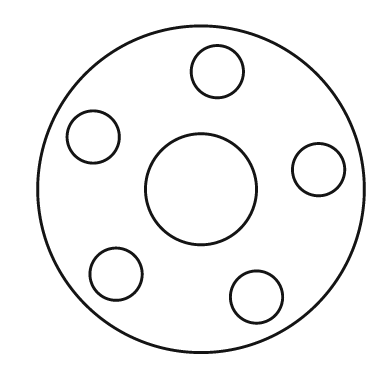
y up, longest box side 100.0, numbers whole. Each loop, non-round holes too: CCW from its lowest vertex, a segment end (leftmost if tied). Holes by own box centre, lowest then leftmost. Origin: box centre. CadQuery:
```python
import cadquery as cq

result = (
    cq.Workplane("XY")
    .moveTo(0.0, 0.0)
    .circle(50.0)
    .moveTo(17.0, -33.0)
    .circle(8.0)
    .moveTo(-26.0, -26.0)
    .circle(8.0)
    .moveTo(0.0, 0.0)
    .circle(17.0)
    .moveTo(36.0, 6.0)
    .circle(8.0)
    .moveTo(-33.0, 16.0)
    .circle(8.0)
    .moveTo(5.0, 36.0)
    .circle(8.0)
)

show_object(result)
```